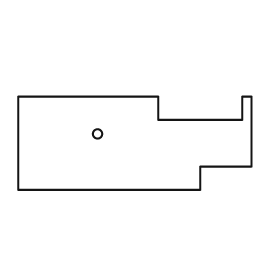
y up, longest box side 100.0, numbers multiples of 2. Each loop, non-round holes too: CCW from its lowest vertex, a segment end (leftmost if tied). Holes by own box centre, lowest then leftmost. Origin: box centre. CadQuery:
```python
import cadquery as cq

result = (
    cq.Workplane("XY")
    .moveTo(-50.0, -20.0)
    .lineTo(28.0, -20.0)
    .lineTo(28.0, -10.0)
    .lineTo(50.0, -10.0)
    .lineTo(50.0, 20.0)
    .lineTo(46.0, 20.0)
    .lineTo(46.0, 10.0)
    .lineTo(10.0, 10.0)
    .lineTo(10.0, 20.0)
    .lineTo(-50.0, 20.0)
    .close()
    .moveTo(-16.0, 4.0)
    .circle(2.0)
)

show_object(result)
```